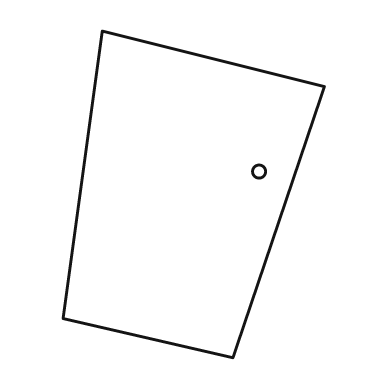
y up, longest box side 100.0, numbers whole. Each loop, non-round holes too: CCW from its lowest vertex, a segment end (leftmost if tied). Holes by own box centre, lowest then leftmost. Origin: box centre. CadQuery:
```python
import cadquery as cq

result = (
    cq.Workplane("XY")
    .moveTo(12.0, -50.0)
    .lineTo(40.0, 33.0)
    .lineTo(-28.0, 50.0)
    .lineTo(-40.0, -38.0)
    .close()
    .moveTo(20.0, 7.0)
    .circle(2.0)
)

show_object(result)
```